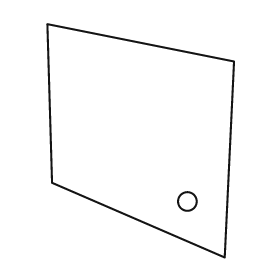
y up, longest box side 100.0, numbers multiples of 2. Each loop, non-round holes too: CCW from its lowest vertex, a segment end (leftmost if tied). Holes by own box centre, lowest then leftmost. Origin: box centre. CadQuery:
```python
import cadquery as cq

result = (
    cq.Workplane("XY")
    .moveTo(36.0, -50.0)
    .lineTo(40.0, 34.0)
    .lineTo(-40.0, 50.0)
    .lineTo(-38.0, -18.0)
    .close()
    .moveTo(20.0, -26.0)
    .circle(4.0)
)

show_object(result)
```